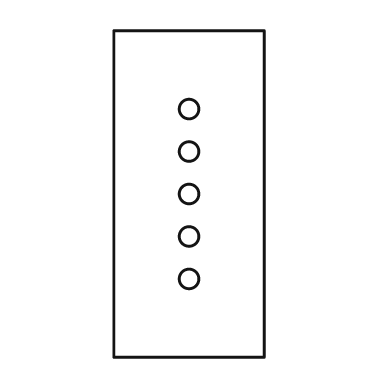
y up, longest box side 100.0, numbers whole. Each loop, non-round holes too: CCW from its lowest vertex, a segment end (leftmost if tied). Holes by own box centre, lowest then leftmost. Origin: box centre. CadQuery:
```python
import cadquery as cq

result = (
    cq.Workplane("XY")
    .moveTo(-23.0, -50.0)
    .lineTo(23.0, -50.0)
    .lineTo(23.0, 50.0)
    .lineTo(-23.0, 50.0)
    .close()
    .moveTo(0.0, -26.0)
    .circle(3.0)
    .moveTo(0.0, -13.0)
    .circle(3.0)
    .moveTo(0.0, 0.0)
    .circle(3.0)
    .moveTo(0.0, 13.0)
    .circle(3.0)
    .moveTo(0.0, 26.0)
    .circle(3.0)
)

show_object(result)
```